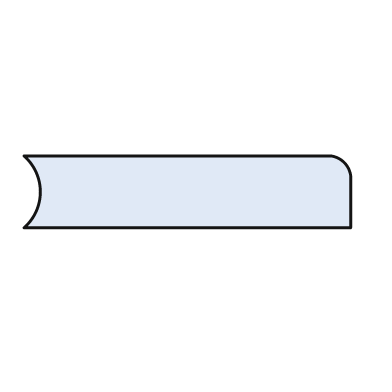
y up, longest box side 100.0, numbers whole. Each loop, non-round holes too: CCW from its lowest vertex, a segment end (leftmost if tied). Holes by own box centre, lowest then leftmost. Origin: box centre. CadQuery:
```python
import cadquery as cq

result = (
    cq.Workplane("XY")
    .moveTo(-50.0, -11.0)
    .lineTo(50.0, -11.0)
    .lineTo(50.0, 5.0)
    .threePointArc((48.0, 9.0), (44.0, 11.0))
    .lineTo(-50.0, 11.0)
    .threePointArc((-45.0, 0.0), (-50.0, -11.0))
    .close()
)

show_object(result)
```